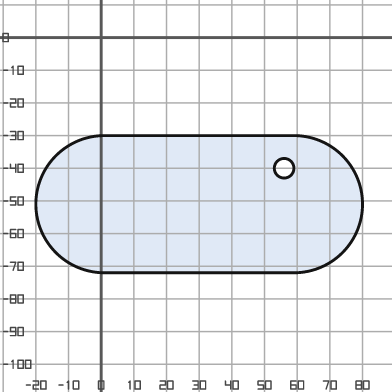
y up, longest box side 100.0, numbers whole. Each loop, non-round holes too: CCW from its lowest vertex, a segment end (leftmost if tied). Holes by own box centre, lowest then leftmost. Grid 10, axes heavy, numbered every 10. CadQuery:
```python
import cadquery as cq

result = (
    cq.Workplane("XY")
    .moveTo(1.0, -72.0)
    .lineTo(59.0, -72.0)
    .threePointArc((80.0, -51.0), (59.0, -30.0))
    .lineTo(1.0, -30.0)
    .threePointArc((-20.0, -51.0), (1.0, -72.0))
    .close()
    .moveTo(56.0, -40.0)
    .circle(3.0)
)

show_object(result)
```